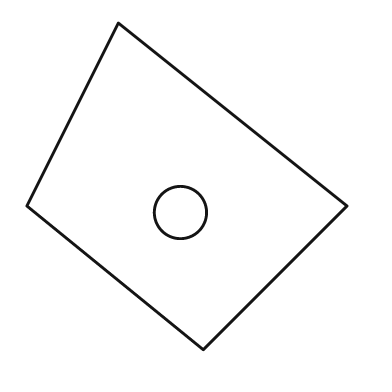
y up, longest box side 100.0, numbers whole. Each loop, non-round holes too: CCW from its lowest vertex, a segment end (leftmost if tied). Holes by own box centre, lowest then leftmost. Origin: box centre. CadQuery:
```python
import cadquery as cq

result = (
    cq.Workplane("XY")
    .moveTo(5.0, -50.0)
    .lineTo(49.0, -6.0)
    .lineTo(-21.0, 50.0)
    .lineTo(-49.0, -6.0)
    .close()
    .moveTo(-2.0, -8.0)
    .circle(8.0)
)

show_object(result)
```